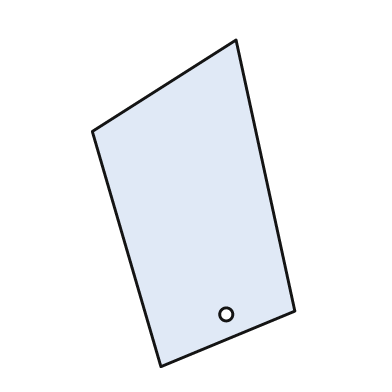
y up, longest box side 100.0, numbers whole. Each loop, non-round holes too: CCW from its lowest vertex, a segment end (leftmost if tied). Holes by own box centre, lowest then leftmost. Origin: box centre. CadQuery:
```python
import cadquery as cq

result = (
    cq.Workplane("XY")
    .moveTo(-10.0, -50.0)
    .lineTo(31.0, -33.0)
    .lineTo(13.0, 50.0)
    .lineTo(-31.0, 22.0)
    .close()
    .moveTo(10.0, -34.0)
    .circle(2.0)
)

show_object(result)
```